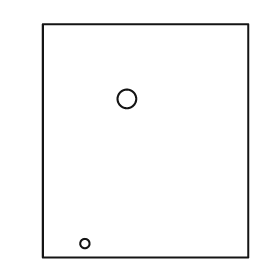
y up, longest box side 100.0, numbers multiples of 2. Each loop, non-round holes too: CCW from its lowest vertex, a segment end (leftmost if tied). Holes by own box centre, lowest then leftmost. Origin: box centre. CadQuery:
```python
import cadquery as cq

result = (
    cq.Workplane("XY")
    .moveTo(-44.0, -50.0)
    .lineTo(44.0, -50.0)
    .lineTo(44.0, 50.0)
    .lineTo(-44.0, 50.0)
    .close()
    .moveTo(-26.0, -44.0)
    .circle(2.0)
    .moveTo(-8.0, 18.0)
    .circle(4.0)
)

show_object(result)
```